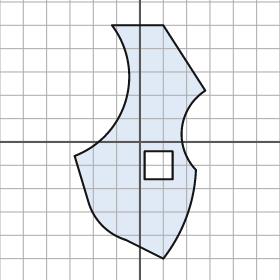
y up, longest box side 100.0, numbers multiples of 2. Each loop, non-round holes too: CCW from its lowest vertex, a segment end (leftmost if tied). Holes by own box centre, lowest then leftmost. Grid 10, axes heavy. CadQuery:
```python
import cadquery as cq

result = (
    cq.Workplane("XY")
    .moveTo(10.0, -50.0)
    .threePointArc((20.0, -32.0), (24.0, -12.0))
    .threePointArc((18.0, 6.0), (28.0, 22.0))
    .lineTo(10.0, 50.0)
    .lineTo(-12.0, 50.0)
    .threePointArc((-6.0, 18.0), (-28.0, -6.0))
    .lineTo(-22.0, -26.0)
    .threePointArc((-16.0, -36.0), (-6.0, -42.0))
    .close()
    .moveTo(2.0, -16.0)
    .lineTo(14.0, -16.0)
    .lineTo(14.0, -4.0)
    .lineTo(2.0, -4.0)
    .close()
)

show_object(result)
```